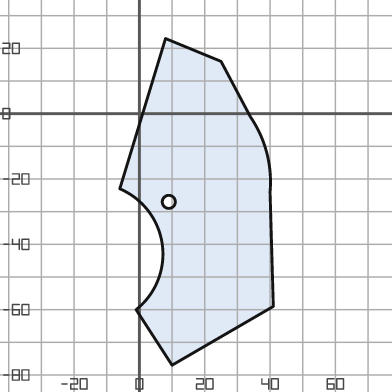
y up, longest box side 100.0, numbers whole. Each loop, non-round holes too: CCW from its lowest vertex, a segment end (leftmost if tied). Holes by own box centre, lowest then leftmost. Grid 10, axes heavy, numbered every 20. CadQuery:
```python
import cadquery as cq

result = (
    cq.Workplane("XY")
    .moveTo(10.0, -77.0)
    .lineTo(41.0, -59.0)
    .lineTo(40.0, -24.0)
    .threePointArc((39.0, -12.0), (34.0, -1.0))
    .lineTo(25.0, 16.0)
    .lineTo(8.0, 23.0)
    .lineTo(-6.0, -23.0)
    .threePointArc((7.0, -40.0), (-1.0, -60.0))
    .close()
    .moveTo(9.0, -27.0)
    .circle(2.0)
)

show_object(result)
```